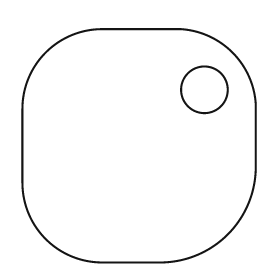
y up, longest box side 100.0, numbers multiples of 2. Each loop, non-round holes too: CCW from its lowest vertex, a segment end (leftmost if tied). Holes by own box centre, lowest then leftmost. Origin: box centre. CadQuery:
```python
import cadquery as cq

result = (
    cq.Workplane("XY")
    .moveTo(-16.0, -50.0)
    .lineTo(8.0, -50.0)
    .threePointArc((38.0, -38.0), (50.0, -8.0))
    .lineTo(50.0, 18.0)
    .threePointArc((40.0, 40.0), (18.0, 50.0))
    .lineTo(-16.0, 50.0)
    .threePointArc((-40.0, 40.0), (-50.0, 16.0))
    .lineTo(-50.0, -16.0)
    .threePointArc((-40.0, -40.0), (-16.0, -50.0))
    .close()
    .moveTo(28.0, 24.0)
    .circle(10.0)
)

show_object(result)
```